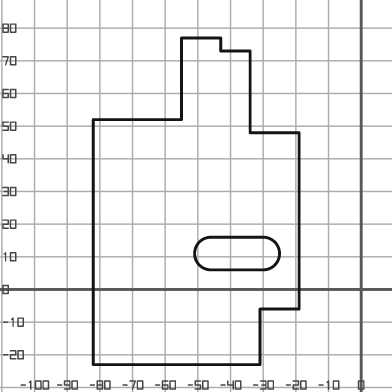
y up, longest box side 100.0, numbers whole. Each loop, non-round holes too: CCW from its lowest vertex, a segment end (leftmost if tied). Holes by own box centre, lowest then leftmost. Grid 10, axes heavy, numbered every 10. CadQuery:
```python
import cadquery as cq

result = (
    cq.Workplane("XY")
    .moveTo(-82.0, -23.0)
    .lineTo(-31.0, -23.0)
    .lineTo(-31.0, -6.0)
    .lineTo(-19.0, -6.0)
    .lineTo(-19.0, 48.0)
    .lineTo(-34.0, 48.0)
    .lineTo(-34.0, 73.0)
    .lineTo(-43.0, 73.0)
    .lineTo(-43.0, 77.0)
    .lineTo(-55.0, 77.0)
    .lineTo(-55.0, 52.0)
    .lineTo(-82.0, 52.0)
    .close()
    .moveTo(-46.0, 6.0)
    .lineTo(-30.0, 6.0)
    .threePointArc((-25.0, 11.0), (-30.0, 16.0))
    .lineTo(-46.0, 16.0)
    .threePointArc((-51.0, 11.0), (-46.0, 6.0))
    .close()
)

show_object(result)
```